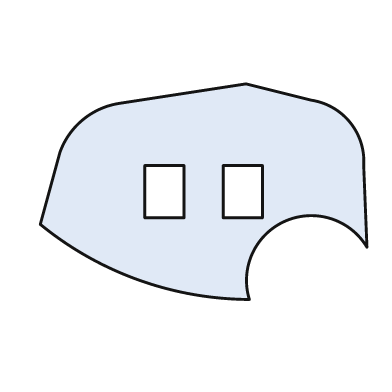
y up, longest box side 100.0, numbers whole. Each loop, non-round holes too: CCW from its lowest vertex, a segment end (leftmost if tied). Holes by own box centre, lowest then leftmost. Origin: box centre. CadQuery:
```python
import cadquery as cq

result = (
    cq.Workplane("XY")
    .moveTo(14.0, -33.0)
    .threePointArc((25.0, -9.0), (50.0, -17.0))
    .lineTo(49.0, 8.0)
    .threePointArc((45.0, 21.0), (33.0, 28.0))
    .lineTo(13.0, 33.0)
    .lineTo(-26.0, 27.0)
    .threePointArc((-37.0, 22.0), (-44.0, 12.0))
    .lineTo(-50.0, -10.0)
    .threePointArc((-20.0, -27.0), (14.0, -33.0))
    .close()
    .moveTo(-18.0, -8.0)
    .lineTo(-6.0, -8.0)
    .lineTo(-6.0, 8.0)
    .lineTo(-18.0, 8.0)
    .close()
    .moveTo(6.0, -8.0)
    .lineTo(18.0, -8.0)
    .lineTo(18.0, 8.0)
    .lineTo(6.0, 8.0)
    .close()
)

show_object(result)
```